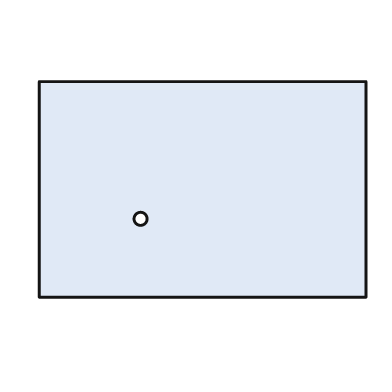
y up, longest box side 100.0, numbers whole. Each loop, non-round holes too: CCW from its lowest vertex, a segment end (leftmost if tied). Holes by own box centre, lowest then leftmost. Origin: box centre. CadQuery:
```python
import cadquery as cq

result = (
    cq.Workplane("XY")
    .moveTo(-50.0, -33.0)
    .lineTo(50.0, -33.0)
    .lineTo(50.0, 33.0)
    .lineTo(-50.0, 33.0)
    .close()
    .moveTo(-19.0, -9.0)
    .circle(2.0)
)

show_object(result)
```